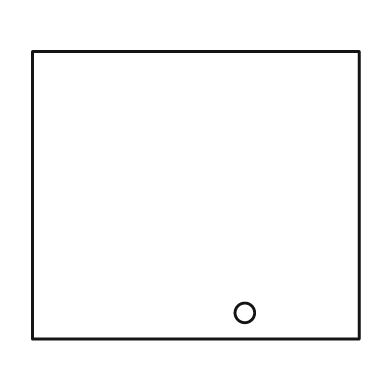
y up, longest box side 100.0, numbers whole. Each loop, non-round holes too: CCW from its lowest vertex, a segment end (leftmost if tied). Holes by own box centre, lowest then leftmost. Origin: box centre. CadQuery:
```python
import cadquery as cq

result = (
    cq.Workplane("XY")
    .moveTo(-50.0, -44.0)
    .lineTo(50.0, -44.0)
    .lineTo(50.0, 44.0)
    .lineTo(-50.0, 44.0)
    .close()
    .moveTo(15.0, -36.0)
    .circle(3.0)
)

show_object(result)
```